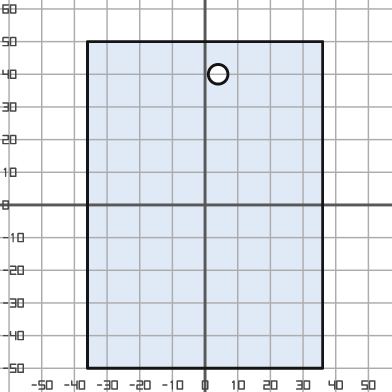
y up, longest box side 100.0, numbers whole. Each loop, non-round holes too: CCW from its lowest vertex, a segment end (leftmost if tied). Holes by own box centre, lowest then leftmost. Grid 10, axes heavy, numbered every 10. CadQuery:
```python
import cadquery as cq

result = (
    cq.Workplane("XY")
    .moveTo(-36.0, -50.0)
    .lineTo(36.0, -50.0)
    .lineTo(36.0, 50.0)
    .lineTo(-36.0, 50.0)
    .close()
    .moveTo(4.0, 40.0)
    .circle(3.0)
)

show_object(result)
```